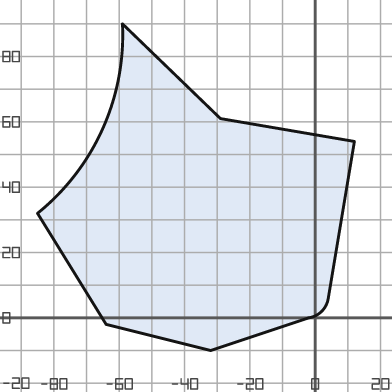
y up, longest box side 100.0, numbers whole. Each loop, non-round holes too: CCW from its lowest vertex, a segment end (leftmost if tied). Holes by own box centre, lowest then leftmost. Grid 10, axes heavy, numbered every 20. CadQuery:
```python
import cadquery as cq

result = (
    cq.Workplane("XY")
    .moveTo(-32.0, -10.0)
    .lineTo(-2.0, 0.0)
    .threePointArc((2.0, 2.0), (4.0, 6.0))
    .lineTo(12.0, 54.0)
    .lineTo(-29.0, 61.0)
    .lineTo(-59.0, 90.0)
    .threePointArc((-65.0, 58.0), (-85.0, 32.0))
    .lineTo(-64.0, -2.0)
    .close()
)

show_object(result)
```